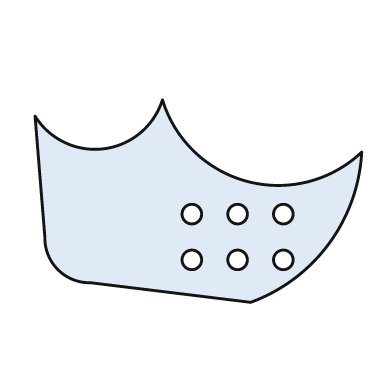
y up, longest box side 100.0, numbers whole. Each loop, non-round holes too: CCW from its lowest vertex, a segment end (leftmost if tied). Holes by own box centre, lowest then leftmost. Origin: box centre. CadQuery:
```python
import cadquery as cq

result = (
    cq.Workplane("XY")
    .moveTo(16.0, -31.0)
    .threePointArc((40.0, -13.0), (50.0, 15.0))
    .threePointArc((15.0, 6.0), (-11.0, 31.0))
    .threePointArc((-29.0, 16.0), (-50.0, 26.0))
    .lineTo(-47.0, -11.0)
    .threePointArc((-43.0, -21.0), (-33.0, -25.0))
    .close()
    .moveTo(-2.0, -18.0)
    .circle(3.0)
    .moveTo(12.0, -18.0)
    .circle(3.0)
    .moveTo(26.0, -18.0)
    .circle(3.0)
    .moveTo(-2.0, -4.0)
    .circle(3.0)
    .moveTo(12.0, -4.0)
    .circle(3.0)
    .moveTo(26.0, -4.0)
    .circle(3.0)
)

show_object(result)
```